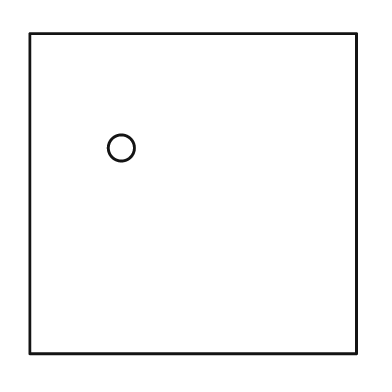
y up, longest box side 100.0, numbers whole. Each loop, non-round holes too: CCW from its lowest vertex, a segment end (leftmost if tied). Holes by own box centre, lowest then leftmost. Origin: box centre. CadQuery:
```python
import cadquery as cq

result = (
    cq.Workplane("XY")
    .moveTo(-50.0, -49.0)
    .lineTo(50.0, -49.0)
    .lineTo(50.0, 49.0)
    .lineTo(-50.0, 49.0)
    .close()
    .moveTo(-22.0, 14.0)
    .circle(4.0)
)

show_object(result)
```